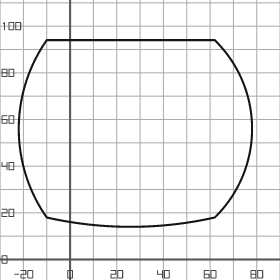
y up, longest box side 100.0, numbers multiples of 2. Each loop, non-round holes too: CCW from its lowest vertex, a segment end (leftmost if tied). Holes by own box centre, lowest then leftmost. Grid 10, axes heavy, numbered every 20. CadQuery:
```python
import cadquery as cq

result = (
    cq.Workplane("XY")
    .moveTo(-10.0, 18.0)
    .threePointArc((26.0, 14.0), (62.0, 18.0))
    .threePointArc((78.0, 56.0), (62.0, 94.0))
    .lineTo(-10.0, 94.0)
    .threePointArc((-22.0, 56.0), (-10.0, 18.0))
    .close()
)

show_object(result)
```